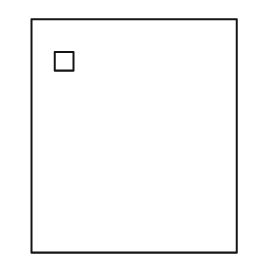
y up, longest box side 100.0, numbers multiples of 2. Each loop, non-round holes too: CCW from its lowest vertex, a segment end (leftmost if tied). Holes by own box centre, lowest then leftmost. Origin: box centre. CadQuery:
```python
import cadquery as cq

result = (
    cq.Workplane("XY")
    .moveTo(-44.0, -50.0)
    .lineTo(44.0, -50.0)
    .lineTo(44.0, 50.0)
    .lineTo(-44.0, 50.0)
    .close()
    .moveTo(-34.0, 28.0)
    .lineTo(-26.0, 28.0)
    .lineTo(-26.0, 36.0)
    .lineTo(-34.0, 36.0)
    .close()
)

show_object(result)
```